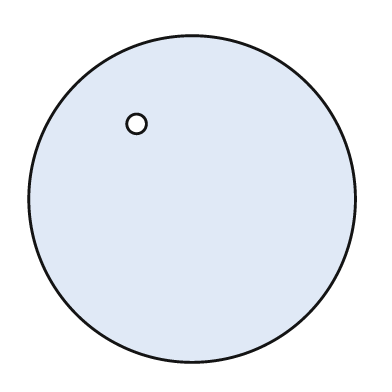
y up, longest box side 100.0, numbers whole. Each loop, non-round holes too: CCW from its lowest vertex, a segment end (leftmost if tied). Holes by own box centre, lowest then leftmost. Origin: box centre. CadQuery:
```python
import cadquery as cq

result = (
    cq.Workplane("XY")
    .moveTo(0.0, 0.0)
    .circle(50.0)
    .moveTo(-17.0, 23.0)
    .circle(3.0)
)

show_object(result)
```